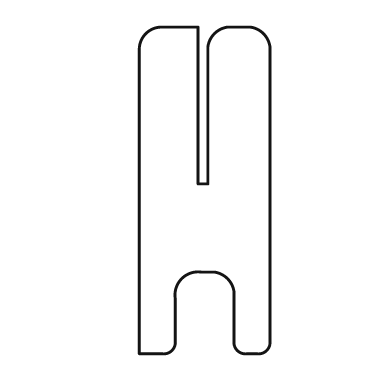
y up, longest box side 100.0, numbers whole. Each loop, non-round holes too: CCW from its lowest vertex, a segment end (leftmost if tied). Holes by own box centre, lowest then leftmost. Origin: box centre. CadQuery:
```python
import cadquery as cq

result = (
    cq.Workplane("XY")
    .moveTo(-20.0, -50.0)
    .lineTo(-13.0, -50.0)
    .threePointArc((-10.0, -49.0), (-9.0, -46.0))
    .lineTo(-9.0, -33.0)
    .threePointArc((-7.0, -27.0), (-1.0, -25.0))
    .lineTo(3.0, -25.0)
    .threePointArc((7.0, -27.0), (9.0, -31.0))
    .lineTo(9.0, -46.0)
    .threePointArc((10.0, -49.0), (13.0, -50.0))
    .lineTo(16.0, -50.0)
    .threePointArc((19.0, -49.0), (20.0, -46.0))
    .lineTo(20.0, 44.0)
    .threePointArc((18.0, 48.0), (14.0, 50.0))
    .lineTo(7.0, 50.0)
    .threePointArc((3.0, 48.0), (1.0, 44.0))
    .lineTo(1.0, 2.0)
    .lineTo(-2.0, 2.0)
    .lineTo(-2.0, 50.0)
    .lineTo(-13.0, 50.0)
    .threePointArc((-18.0, 48.0), (-20.0, 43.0))
    .close()
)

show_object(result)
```